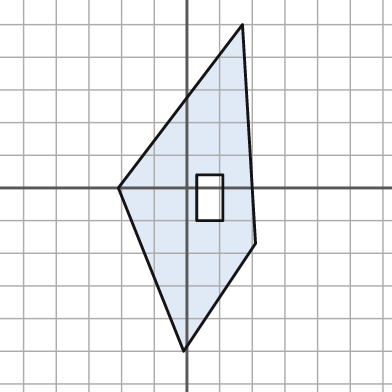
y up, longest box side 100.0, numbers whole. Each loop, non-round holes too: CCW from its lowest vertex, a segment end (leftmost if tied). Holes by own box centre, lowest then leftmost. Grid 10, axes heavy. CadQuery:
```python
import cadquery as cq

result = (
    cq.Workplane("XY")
    .moveTo(-1.0, -50.0)
    .lineTo(21.0, -17.0)
    .lineTo(17.0, 50.0)
    .lineTo(-21.0, 0.0)
    .close()
    .moveTo(3.0, -10.0)
    .lineTo(11.0, -10.0)
    .lineTo(11.0, 4.0)
    .lineTo(3.0, 4.0)
    .close()
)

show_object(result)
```